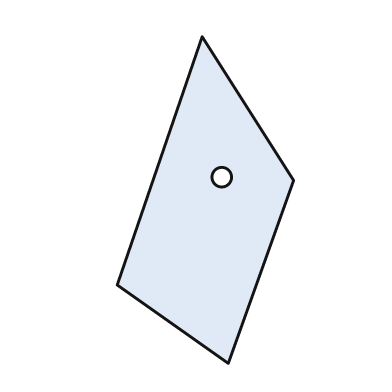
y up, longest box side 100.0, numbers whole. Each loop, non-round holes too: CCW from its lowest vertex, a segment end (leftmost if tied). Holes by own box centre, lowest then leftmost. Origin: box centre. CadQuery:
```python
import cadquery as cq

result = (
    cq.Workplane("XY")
    .moveTo(7.0, -50.0)
    .lineTo(27.0, 6.0)
    .lineTo(-1.0, 50.0)
    .lineTo(-27.0, -26.0)
    .close()
    .moveTo(5.0, 7.0)
    .circle(3.0)
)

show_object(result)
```